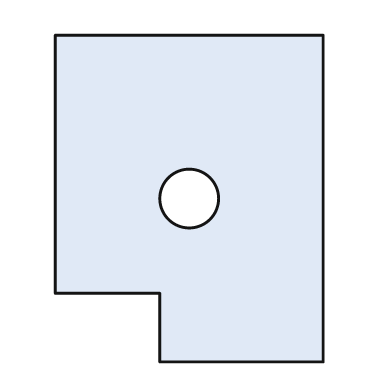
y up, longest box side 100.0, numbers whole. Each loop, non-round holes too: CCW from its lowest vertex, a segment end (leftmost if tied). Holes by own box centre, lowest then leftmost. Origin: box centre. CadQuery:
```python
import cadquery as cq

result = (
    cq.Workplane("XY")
    .moveTo(-9.0, -50.0)
    .lineTo(41.0, -50.0)
    .lineTo(41.0, 50.0)
    .lineTo(-41.0, 50.0)
    .lineTo(-41.0, -29.0)
    .lineTo(-9.0, -29.0)
    .close()
    .moveTo(0.0, 0.0)
    .circle(9.0)
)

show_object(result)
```